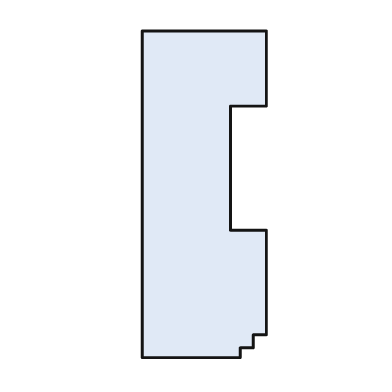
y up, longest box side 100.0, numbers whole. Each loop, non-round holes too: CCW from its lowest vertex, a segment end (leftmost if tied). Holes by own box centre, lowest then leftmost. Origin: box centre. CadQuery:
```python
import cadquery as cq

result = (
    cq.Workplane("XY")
    .moveTo(-19.0, -50.0)
    .lineTo(11.0, -50.0)
    .lineTo(11.0, -47.0)
    .lineTo(15.0, -47.0)
    .lineTo(15.0, -43.0)
    .lineTo(19.0, -43.0)
    .lineTo(19.0, -11.0)
    .lineTo(8.0, -11.0)
    .lineTo(8.0, 27.0)
    .lineTo(19.0, 27.0)
    .lineTo(19.0, 50.0)
    .lineTo(-19.0, 50.0)
    .close()
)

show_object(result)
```